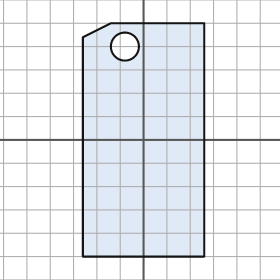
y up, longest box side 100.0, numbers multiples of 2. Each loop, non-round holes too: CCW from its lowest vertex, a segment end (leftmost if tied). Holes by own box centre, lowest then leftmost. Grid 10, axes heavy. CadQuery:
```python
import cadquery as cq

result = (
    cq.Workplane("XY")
    .moveTo(-26.0, -50.0)
    .lineTo(26.0, -50.0)
    .lineTo(26.0, 50.0)
    .lineTo(-14.0, 50.0)
    .lineTo(-26.0, 44.0)
    .close()
    .moveTo(-8.0, 40.0)
    .circle(6.0)
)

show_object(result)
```